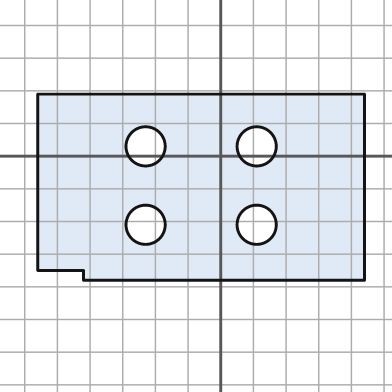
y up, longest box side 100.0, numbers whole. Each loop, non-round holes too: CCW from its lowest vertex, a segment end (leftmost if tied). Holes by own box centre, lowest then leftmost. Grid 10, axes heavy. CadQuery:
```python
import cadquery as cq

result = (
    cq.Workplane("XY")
    .moveTo(-42.0, -38.0)
    .lineTo(44.0, -38.0)
    .lineTo(44.0, 19.0)
    .lineTo(-56.0, 19.0)
    .lineTo(-56.0, -35.0)
    .lineTo(-42.0, -35.0)
    .close()
    .moveTo(-23.0, -21.0)
    .circle(6.0)
    .moveTo(11.0, -21.0)
    .circle(6.0)
    .moveTo(-23.0, 3.0)
    .circle(6.0)
    .moveTo(11.0, 3.0)
    .circle(6.0)
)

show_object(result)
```